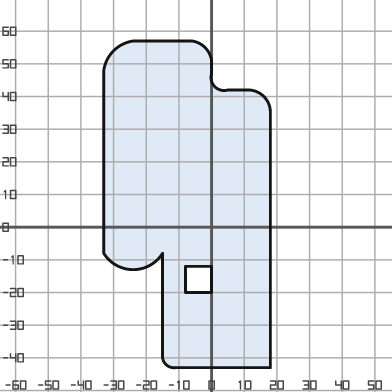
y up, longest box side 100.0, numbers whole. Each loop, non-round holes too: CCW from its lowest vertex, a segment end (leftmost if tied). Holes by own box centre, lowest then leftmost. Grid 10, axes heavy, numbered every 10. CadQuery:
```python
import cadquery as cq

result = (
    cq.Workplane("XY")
    .moveTo(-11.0, -43.0)
    .lineTo(18.0, -43.0)
    .lineTo(18.0, 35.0)
    .threePointArc((16.0, 40.0), (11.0, 42.0))
    .lineTo(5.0, 42.0)
    .threePointArc((1.0, 43.0), (0.0, 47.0))
    .lineTo(0.0, 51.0)
    .threePointArc((-2.0, 55.0), (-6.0, 57.0))
    .lineTo(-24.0, 57.0)
    .threePointArc((-30.0, 54.0), (-33.0, 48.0))
    .lineTo(-33.0, -8.0)
    .threePointArc((-24.0, -13.0), (-15.0, -8.0))
    .lineTo(-15.0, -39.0)
    .threePointArc((-14.0, -42.0), (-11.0, -43.0))
    .close()
    .moveTo(-8.0, -20.0)
    .lineTo(0.0, -20.0)
    .lineTo(0.0, -12.0)
    .lineTo(-8.0, -12.0)
    .close()
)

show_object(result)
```